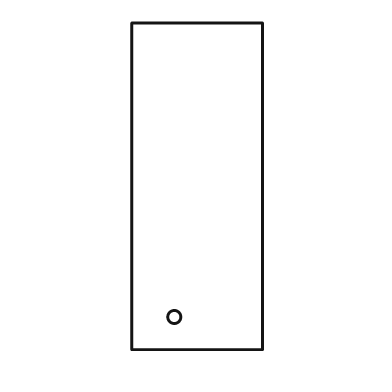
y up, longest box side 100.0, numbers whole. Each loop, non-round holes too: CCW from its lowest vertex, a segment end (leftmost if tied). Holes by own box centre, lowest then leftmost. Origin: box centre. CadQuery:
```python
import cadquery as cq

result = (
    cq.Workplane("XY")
    .moveTo(-20.0, -50.0)
    .lineTo(20.0, -50.0)
    .lineTo(20.0, 50.0)
    .lineTo(-20.0, 50.0)
    .close()
    .moveTo(-7.0, -40.0)
    .circle(2.0)
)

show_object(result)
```